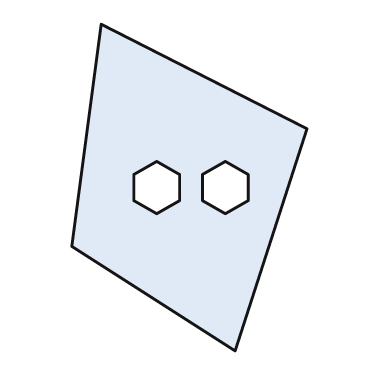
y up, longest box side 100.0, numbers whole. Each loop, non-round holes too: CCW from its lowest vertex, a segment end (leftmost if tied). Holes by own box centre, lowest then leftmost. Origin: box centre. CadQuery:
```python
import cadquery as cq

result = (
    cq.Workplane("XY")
    .moveTo(14.0, -50.0)
    .lineTo(36.0, 18.0)
    .lineTo(-27.0, 50.0)
    .lineTo(-36.0, -18.0)
    .close()
    .moveTo(-10.0, -8.0)
    .lineTo(-3.0, -4.0)
    .lineTo(-3.0, 4.0)
    .lineTo(-10.0, 8.0)
    .lineTo(-17.0, 4.0)
    .lineTo(-17.0, -4.0)
    .close()
    .moveTo(11.0, -8.0)
    .lineTo(18.0, -4.0)
    .lineTo(18.0, 4.0)
    .lineTo(11.0, 8.0)
    .lineTo(4.0, 4.0)
    .lineTo(4.0, -4.0)
    .close()
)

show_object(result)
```